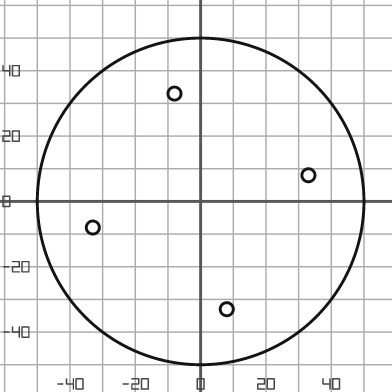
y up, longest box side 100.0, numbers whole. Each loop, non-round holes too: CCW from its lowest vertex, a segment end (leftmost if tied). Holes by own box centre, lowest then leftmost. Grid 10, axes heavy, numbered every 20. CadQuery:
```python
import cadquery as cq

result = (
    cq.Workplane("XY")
    .moveTo(0.0, 0.0)
    .circle(50.0)
    .moveTo(8.0, -33.0)
    .circle(2.0)
    .moveTo(-33.0, -8.0)
    .circle(2.0)
    .moveTo(33.0, 8.0)
    .circle(2.0)
    .moveTo(-8.0, 33.0)
    .circle(2.0)
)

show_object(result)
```